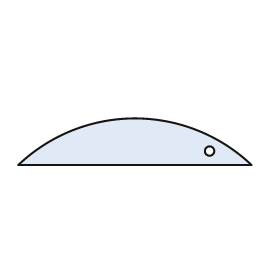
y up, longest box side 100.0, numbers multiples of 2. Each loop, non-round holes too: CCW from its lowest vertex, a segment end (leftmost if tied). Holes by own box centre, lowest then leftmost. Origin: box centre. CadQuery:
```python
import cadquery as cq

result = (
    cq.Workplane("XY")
    .moveTo(-50.0, -10.0)
    .lineTo(50.0, -10.0)
    .threePointArc((0.0, 10.0), (-50.0, -10.0))
    .close()
    .moveTo(32.0, -4.0)
    .circle(2.0)
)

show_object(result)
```